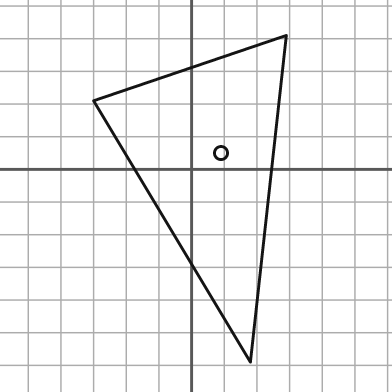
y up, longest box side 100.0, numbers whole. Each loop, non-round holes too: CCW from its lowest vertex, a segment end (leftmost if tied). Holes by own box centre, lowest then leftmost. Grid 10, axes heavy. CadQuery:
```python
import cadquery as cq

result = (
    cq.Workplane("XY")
    .moveTo(18.0, -59.0)
    .lineTo(29.0, 41.0)
    .lineTo(-30.0, 21.0)
    .close()
    .moveTo(9.0, 5.0)
    .circle(2.0)
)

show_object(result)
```